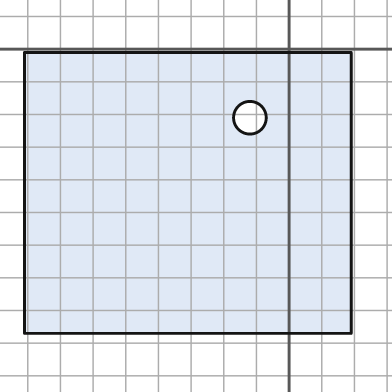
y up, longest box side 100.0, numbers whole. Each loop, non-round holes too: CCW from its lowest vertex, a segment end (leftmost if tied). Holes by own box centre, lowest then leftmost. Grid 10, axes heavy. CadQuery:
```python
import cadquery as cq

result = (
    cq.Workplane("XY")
    .moveTo(-81.0, -87.0)
    .lineTo(19.0, -87.0)
    .lineTo(19.0, -1.0)
    .lineTo(-81.0, -1.0)
    .close()
    .moveTo(-12.0, -21.0)
    .circle(5.0)
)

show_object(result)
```